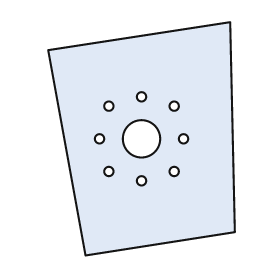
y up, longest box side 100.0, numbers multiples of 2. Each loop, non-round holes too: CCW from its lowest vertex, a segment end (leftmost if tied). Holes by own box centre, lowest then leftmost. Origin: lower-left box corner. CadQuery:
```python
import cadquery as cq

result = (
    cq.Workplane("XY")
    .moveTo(16.0, 0.0)
    .lineTo(80.0, 10.0)
    .lineTo(78.0, 100.0)
    .lineTo(0.0, 88.0)
    .close()
    .moveTo(40.0, 32.0)
    .circle(2.0)
    .moveTo(26.0, 36.0)
    .circle(2.0)
    .moveTo(54.0, 36.0)
    .circle(2.0)
    .moveTo(22.0, 50.0)
    .circle(2.0)
    .moveTo(40.0, 50.0)
    .circle(8.0)
    .moveTo(58.0, 50.0)
    .circle(2.0)
    .moveTo(26.0, 64.0)
    .circle(2.0)
    .moveTo(54.0, 64.0)
    .circle(2.0)
    .moveTo(40.0, 68.0)
    .circle(2.0)
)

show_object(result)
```